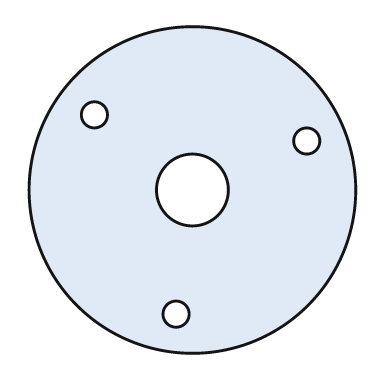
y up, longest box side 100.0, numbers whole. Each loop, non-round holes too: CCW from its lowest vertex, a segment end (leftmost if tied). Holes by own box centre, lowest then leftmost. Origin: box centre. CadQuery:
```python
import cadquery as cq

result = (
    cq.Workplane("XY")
    .moveTo(0.0, 0.0)
    .circle(50.0)
    .moveTo(-5.0, -38.0)
    .circle(4.0)
    .moveTo(0.0, 0.0)
    .circle(11.0)
    .moveTo(35.0, 15.0)
    .circle(4.0)
    .moveTo(-30.0, 23.0)
    .circle(4.0)
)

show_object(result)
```